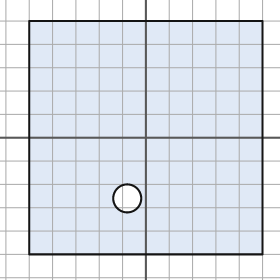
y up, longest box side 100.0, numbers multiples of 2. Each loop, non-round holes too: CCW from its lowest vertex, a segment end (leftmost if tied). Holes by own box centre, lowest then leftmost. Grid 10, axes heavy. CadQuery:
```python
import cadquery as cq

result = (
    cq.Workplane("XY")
    .moveTo(-50.0, -50.0)
    .lineTo(50.0, -50.0)
    .lineTo(50.0, 50.0)
    .lineTo(-50.0, 50.0)
    .close()
    .moveTo(-8.0, -26.0)
    .circle(6.0)
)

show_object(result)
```